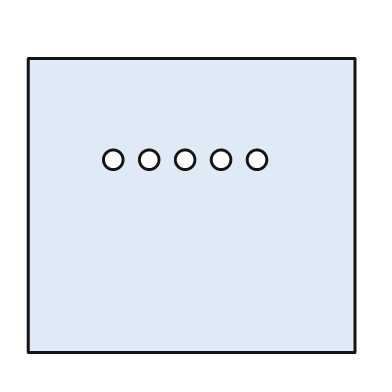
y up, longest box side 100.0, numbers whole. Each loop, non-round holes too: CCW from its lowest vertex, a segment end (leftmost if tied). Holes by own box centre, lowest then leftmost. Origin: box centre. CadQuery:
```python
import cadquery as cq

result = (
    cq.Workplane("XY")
    .moveTo(-50.0, -45.0)
    .lineTo(50.0, -45.0)
    .lineTo(50.0, 45.0)
    .lineTo(-50.0, 45.0)
    .close()
    .moveTo(-24.0, 14.0)
    .circle(3.0)
    .moveTo(-13.0, 14.0)
    .circle(3.0)
    .moveTo(-2.0, 14.0)
    .circle(3.0)
    .moveTo(9.0, 14.0)
    .circle(3.0)
    .moveTo(20.0, 14.0)
    .circle(3.0)
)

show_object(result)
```